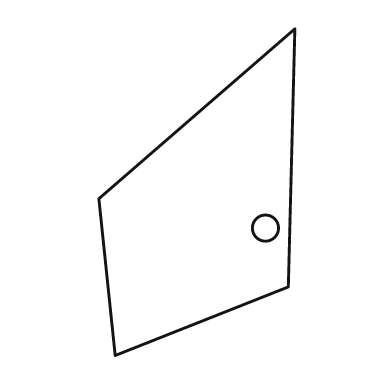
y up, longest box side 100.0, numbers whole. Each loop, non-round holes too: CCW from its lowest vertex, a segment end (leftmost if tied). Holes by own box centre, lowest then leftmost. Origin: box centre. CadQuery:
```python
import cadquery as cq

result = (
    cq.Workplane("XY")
    .moveTo(-25.0, -50.0)
    .lineTo(28.0, -29.0)
    .lineTo(30.0, 50.0)
    .lineTo(-30.0, -2.0)
    .close()
    .moveTo(21.0, -11.0)
    .circle(4.0)
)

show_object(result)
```